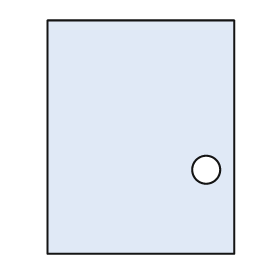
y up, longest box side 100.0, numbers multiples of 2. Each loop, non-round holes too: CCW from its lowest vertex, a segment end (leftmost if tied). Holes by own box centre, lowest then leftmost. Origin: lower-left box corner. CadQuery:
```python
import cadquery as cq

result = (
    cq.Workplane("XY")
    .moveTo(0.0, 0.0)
    .lineTo(80.0, 0.0)
    .lineTo(80.0, 100.0)
    .lineTo(0.0, 100.0)
    .close()
    .moveTo(68.0, 36.0)
    .circle(6.0)
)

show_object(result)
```